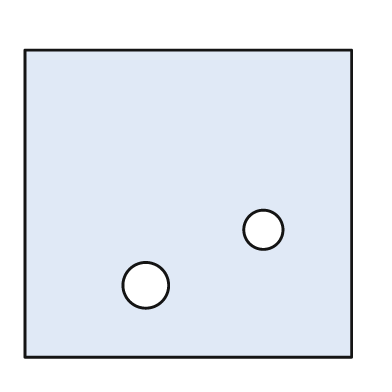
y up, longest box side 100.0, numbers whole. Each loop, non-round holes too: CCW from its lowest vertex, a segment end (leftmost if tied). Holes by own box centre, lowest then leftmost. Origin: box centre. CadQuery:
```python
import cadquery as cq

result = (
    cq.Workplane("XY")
    .moveTo(-50.0, -47.0)
    .lineTo(50.0, -47.0)
    .lineTo(50.0, 47.0)
    .lineTo(-50.0, 47.0)
    .close()
    .moveTo(-13.0, -25.0)
    .circle(7.0)
    .moveTo(23.0, -8.0)
    .circle(6.0)
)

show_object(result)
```